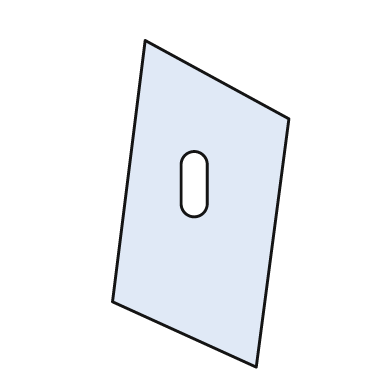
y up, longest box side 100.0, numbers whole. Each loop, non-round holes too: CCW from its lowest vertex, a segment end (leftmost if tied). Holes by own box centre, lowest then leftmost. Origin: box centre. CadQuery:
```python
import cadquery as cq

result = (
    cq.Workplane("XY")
    .moveTo(17.0, -50.0)
    .lineTo(27.0, 26.0)
    .lineTo(-17.0, 50.0)
    .lineTo(-27.0, -30.0)
    .close()
    .moveTo(-6.0, 0.0)
    .threePointArc((-2.0, -4.0), (2.0, 0.0))
    .lineTo(2.0, 12.0)
    .threePointArc((-2.0, 16.0), (-6.0, 12.0))
    .close()
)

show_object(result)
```